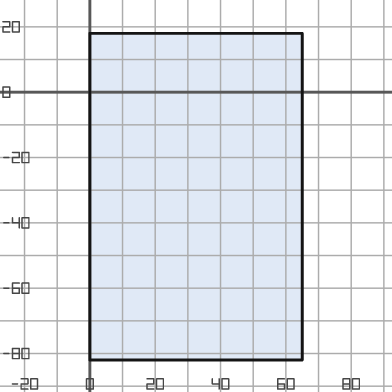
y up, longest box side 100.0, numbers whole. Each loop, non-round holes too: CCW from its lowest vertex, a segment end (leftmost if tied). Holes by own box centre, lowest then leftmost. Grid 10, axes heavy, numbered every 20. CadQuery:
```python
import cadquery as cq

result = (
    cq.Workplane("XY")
    .moveTo(0.0, -82.0)
    .lineTo(65.0, -82.0)
    .lineTo(65.0, 18.0)
    .lineTo(0.0, 18.0)
    .close()
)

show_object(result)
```